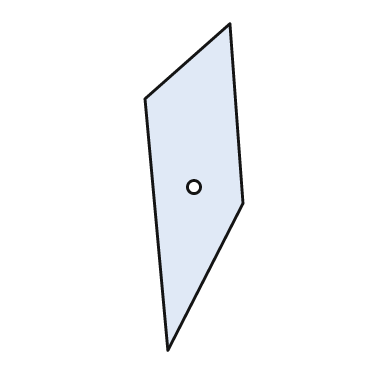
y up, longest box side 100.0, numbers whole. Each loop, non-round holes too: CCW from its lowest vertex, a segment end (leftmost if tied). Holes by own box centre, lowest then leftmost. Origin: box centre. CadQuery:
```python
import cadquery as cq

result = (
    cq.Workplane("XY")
    .moveTo(-8.0, -50.0)
    .lineTo(15.0, -5.0)
    .lineTo(11.0, 50.0)
    .lineTo(-15.0, 27.0)
    .close()
    .moveTo(0.0, 0.0)
    .circle(2.0)
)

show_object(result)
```